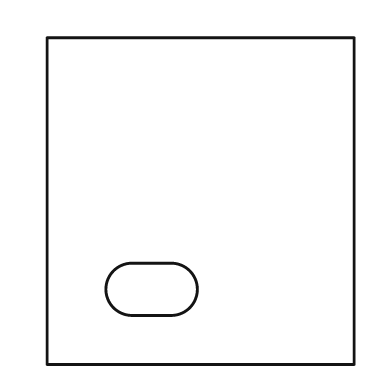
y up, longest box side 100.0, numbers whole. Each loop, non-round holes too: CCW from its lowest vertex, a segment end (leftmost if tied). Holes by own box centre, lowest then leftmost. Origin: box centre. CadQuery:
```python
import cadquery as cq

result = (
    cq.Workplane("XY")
    .moveTo(-47.0, -50.0)
    .lineTo(47.0, -50.0)
    .lineTo(47.0, 50.0)
    .lineTo(-47.0, 50.0)
    .close()
    .moveTo(-21.0, -35.0)
    .lineTo(-9.0, -35.0)
    .threePointArc((-1.0, -27.0), (-9.0, -19.0))
    .lineTo(-21.0, -19.0)
    .threePointArc((-29.0, -27.0), (-21.0, -35.0))
    .close()
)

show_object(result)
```